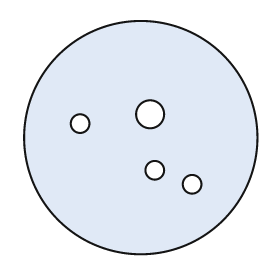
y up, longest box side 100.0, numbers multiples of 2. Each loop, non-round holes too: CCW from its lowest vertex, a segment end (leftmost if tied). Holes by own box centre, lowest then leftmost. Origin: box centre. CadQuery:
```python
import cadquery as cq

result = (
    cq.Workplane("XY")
    .moveTo(0.0, 0.0)
    .circle(50.0)
    .moveTo(22.0, -20.0)
    .circle(4.0)
    .moveTo(6.0, -14.0)
    .circle(4.0)
    .moveTo(-26.0, 6.0)
    .circle(4.0)
    .moveTo(4.0, 10.0)
    .circle(6.0)
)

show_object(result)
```